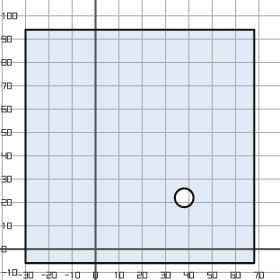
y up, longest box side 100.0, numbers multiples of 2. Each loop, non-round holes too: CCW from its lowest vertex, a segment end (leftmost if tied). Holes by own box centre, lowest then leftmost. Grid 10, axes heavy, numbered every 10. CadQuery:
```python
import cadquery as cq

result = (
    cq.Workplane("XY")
    .moveTo(-30.0, -6.0)
    .lineTo(68.0, -6.0)
    .lineTo(68.0, 94.0)
    .lineTo(-30.0, 94.0)
    .close()
    .moveTo(38.0, 22.0)
    .circle(4.0)
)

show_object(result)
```